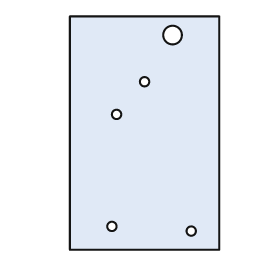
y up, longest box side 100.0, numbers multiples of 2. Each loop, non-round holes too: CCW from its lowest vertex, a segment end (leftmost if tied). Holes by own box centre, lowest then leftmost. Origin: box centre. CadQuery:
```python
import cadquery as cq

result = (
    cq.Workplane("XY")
    .moveTo(-32.0, -50.0)
    .lineTo(32.0, -50.0)
    .lineTo(32.0, 50.0)
    .lineTo(-32.0, 50.0)
    .close()
    .moveTo(20.0, -42.0)
    .circle(2.0)
    .moveTo(-14.0, -40.0)
    .circle(2.0)
    .moveTo(-12.0, 8.0)
    .circle(2.0)
    .moveTo(0.0, 22.0)
    .circle(2.0)
    .moveTo(12.0, 42.0)
    .circle(4.0)
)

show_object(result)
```